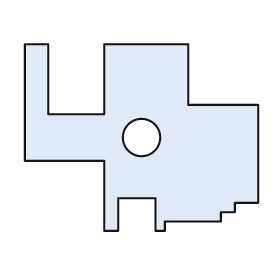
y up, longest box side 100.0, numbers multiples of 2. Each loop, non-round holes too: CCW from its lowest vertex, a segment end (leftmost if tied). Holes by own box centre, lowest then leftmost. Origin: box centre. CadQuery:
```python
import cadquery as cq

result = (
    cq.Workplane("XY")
    .moveTo(-16.0, -40.0)
    .lineTo(-10.0, -40.0)
    .lineTo(-10.0, -26.0)
    .lineTo(6.0, -26.0)
    .lineTo(6.0, -40.0)
    .lineTo(10.0, -40.0)
    .lineTo(10.0, -36.0)
    .lineTo(34.0, -36.0)
    .lineTo(34.0, -32.0)
    .lineTo(40.0, -32.0)
    .lineTo(40.0, -28.0)
    .lineTo(50.0, -28.0)
    .lineTo(50.0, 14.0)
    .lineTo(20.0, 14.0)
    .lineTo(20.0, 40.0)
    .lineTo(-16.0, 40.0)
    .lineTo(-16.0, 10.0)
    .lineTo(-40.0, 10.0)
    .lineTo(-40.0, 40.0)
    .lineTo(-50.0, 40.0)
    .lineTo(-50.0, -10.0)
    .lineTo(-16.0, -10.0)
    .close()
    .moveTo(0.0, 0.0)
    .circle(8.0)
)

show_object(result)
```